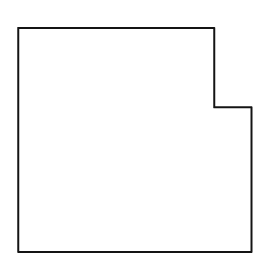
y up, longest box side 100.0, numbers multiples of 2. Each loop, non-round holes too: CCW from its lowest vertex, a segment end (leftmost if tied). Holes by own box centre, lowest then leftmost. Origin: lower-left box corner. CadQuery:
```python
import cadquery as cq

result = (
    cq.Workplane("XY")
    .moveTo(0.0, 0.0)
    .lineTo(100.0, 0.0)
    .lineTo(100.0, 62.0)
    .lineTo(84.0, 62.0)
    .lineTo(84.0, 96.0)
    .lineTo(0.0, 96.0)
    .close()
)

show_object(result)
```